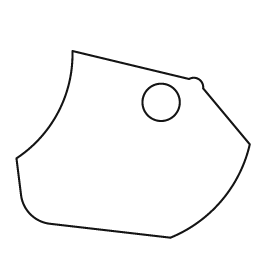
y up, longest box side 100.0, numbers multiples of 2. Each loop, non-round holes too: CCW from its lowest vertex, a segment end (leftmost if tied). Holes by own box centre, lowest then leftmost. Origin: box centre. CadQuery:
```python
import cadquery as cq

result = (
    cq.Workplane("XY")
    .moveTo(16.0, -40.0)
    .threePointArc((38.0, -24.0), (50.0, 0.0))
    .lineTo(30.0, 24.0)
    .threePointArc((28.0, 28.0), (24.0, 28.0))
    .lineTo(-26.0, 40.0)
    .threePointArc((-32.0, 14.0), (-50.0, -6.0))
    .lineTo(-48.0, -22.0)
    .threePointArc((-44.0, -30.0), (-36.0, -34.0))
    .close()
    .moveTo(12.0, 18.0)
    .circle(8.0)
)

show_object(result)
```